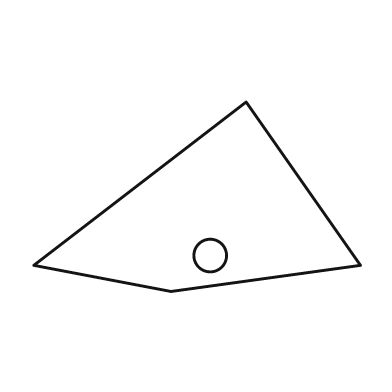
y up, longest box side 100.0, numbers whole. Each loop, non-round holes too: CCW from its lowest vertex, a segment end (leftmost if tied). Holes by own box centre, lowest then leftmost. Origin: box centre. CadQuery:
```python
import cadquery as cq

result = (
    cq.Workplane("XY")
    .moveTo(-8.0, -29.0)
    .lineTo(50.0, -21.0)
    .lineTo(15.0, 29.0)
    .lineTo(-50.0, -21.0)
    .close()
    .moveTo(4.0, -18.0)
    .circle(5.0)
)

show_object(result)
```